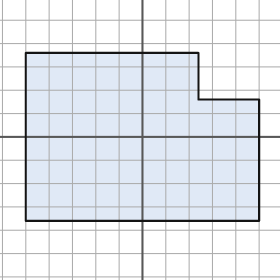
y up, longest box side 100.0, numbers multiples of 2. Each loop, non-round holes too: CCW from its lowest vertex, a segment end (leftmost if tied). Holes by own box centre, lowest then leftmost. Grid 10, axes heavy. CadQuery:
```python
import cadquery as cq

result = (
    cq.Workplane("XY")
    .moveTo(-50.0, -36.0)
    .lineTo(50.0, -36.0)
    .lineTo(50.0, 16.0)
    .lineTo(24.0, 16.0)
    .lineTo(24.0, 36.0)
    .lineTo(-50.0, 36.0)
    .close()
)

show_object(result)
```